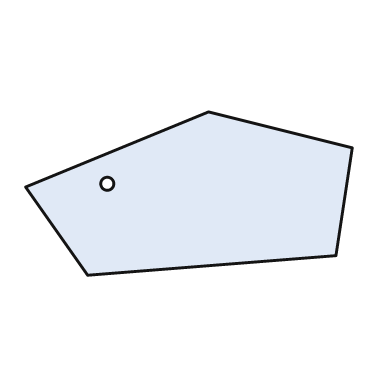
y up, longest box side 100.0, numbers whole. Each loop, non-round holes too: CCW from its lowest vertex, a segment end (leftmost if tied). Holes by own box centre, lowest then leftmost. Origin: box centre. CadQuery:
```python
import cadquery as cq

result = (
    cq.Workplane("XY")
    .moveTo(-31.0, -25.0)
    .lineTo(45.0, -19.0)
    .lineTo(50.0, 14.0)
    .lineTo(6.0, 25.0)
    .lineTo(-50.0, 2.0)
    .close()
    .moveTo(-25.0, 3.0)
    .circle(2.0)
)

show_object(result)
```